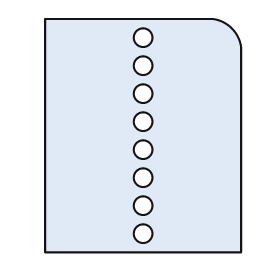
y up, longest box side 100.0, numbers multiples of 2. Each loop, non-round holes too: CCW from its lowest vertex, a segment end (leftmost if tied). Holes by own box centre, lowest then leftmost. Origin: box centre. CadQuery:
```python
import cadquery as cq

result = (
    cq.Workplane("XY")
    .moveTo(-42.0, -50.0)
    .lineTo(42.0, -50.0)
    .lineTo(42.0, 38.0)
    .threePointArc((38.0, 46.0), (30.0, 50.0))
    .lineTo(-42.0, 50.0)
    .close()
    .moveTo(0.0, -42.0)
    .circle(4.0)
    .moveTo(0.0, -30.0)
    .circle(4.0)
    .moveTo(0.0, -18.0)
    .circle(4.0)
    .moveTo(0.0, -6.0)
    .circle(4.0)
    .moveTo(0.0, 6.0)
    .circle(4.0)
    .moveTo(0.0, 18.0)
    .circle(4.0)
    .moveTo(0.0, 30.0)
    .circle(4.0)
    .moveTo(0.0, 42.0)
    .circle(4.0)
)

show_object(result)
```